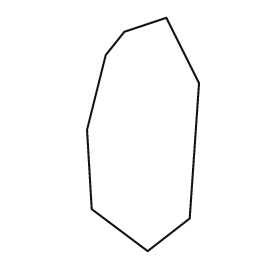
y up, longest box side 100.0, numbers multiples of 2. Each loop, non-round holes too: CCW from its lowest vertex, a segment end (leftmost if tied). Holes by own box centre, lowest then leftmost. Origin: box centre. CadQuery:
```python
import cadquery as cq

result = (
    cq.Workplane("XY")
    .moveTo(2.0, -50.0)
    .lineTo(20.0, -36.0)
    .lineTo(24.0, 22.0)
    .lineTo(10.0, 50.0)
    .lineTo(-8.0, 44.0)
    .lineTo(-16.0, 34.0)
    .lineTo(-24.0, 2.0)
    .lineTo(-22.0, -32.0)
    .close()
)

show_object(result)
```